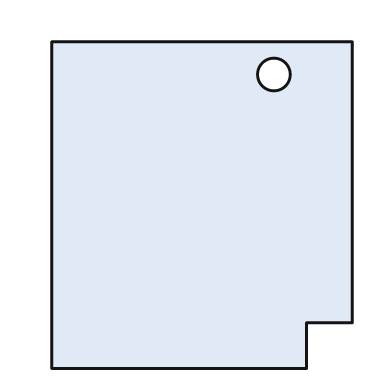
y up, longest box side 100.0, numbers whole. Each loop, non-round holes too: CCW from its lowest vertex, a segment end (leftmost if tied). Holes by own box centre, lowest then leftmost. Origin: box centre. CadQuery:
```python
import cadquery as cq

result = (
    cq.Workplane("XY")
    .moveTo(-46.0, -50.0)
    .lineTo(32.0, -50.0)
    .lineTo(32.0, -36.0)
    .lineTo(46.0, -36.0)
    .lineTo(46.0, 50.0)
    .lineTo(-46.0, 50.0)
    .close()
    .moveTo(22.0, 40.0)
    .circle(5.0)
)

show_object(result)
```